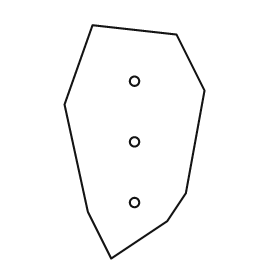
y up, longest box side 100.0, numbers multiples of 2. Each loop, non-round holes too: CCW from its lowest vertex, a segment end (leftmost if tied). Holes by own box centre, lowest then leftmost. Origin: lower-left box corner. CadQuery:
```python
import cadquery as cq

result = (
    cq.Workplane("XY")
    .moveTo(20.0, 0.0)
    .lineTo(44.0, 16.0)
    .lineTo(52.0, 28.0)
    .lineTo(60.0, 72.0)
    .lineTo(48.0, 96.0)
    .lineTo(12.0, 100.0)
    .lineTo(0.0, 66.0)
    .lineTo(10.0, 20.0)
    .close()
    .moveTo(30.0, 24.0)
    .circle(2.0)
    .moveTo(30.0, 50.0)
    .circle(2.0)
    .moveTo(30.0, 76.0)
    .circle(2.0)
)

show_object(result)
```